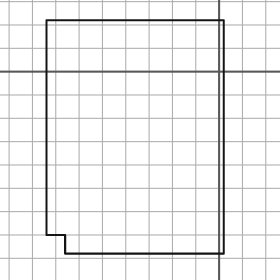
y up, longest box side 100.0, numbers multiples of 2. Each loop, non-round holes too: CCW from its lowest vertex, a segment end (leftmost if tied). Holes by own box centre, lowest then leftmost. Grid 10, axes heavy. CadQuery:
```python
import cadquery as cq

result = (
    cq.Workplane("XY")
    .moveTo(-66.0, -78.0)
    .lineTo(2.0, -78.0)
    .lineTo(2.0, 22.0)
    .lineTo(-74.0, 22.0)
    .lineTo(-74.0, -70.0)
    .lineTo(-66.0, -70.0)
    .close()
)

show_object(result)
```